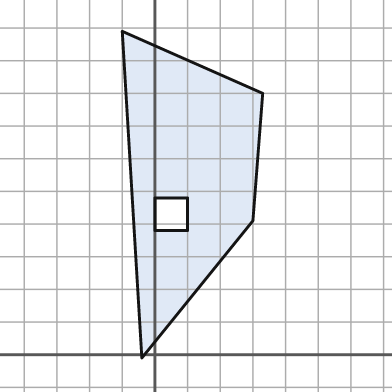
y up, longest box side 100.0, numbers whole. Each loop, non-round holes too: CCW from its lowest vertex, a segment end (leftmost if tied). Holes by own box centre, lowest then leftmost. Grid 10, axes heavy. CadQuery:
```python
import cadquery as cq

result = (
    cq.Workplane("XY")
    .moveTo(-4.0, -1.0)
    .lineTo(30.0, 41.0)
    .lineTo(33.0, 80.0)
    .lineTo(-10.0, 99.0)
    .close()
    .moveTo(0.0, 38.0)
    .lineTo(10.0, 38.0)
    .lineTo(10.0, 48.0)
    .lineTo(0.0, 48.0)
    .close()
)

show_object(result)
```